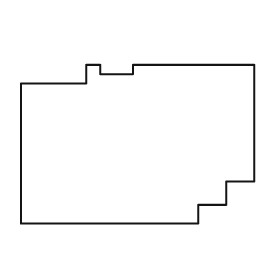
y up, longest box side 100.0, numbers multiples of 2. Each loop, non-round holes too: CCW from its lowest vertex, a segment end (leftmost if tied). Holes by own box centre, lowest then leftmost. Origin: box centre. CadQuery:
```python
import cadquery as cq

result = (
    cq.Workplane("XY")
    .moveTo(-50.0, -34.0)
    .lineTo(26.0, -34.0)
    .lineTo(26.0, -26.0)
    .lineTo(38.0, -26.0)
    .lineTo(38.0, -16.0)
    .lineTo(50.0, -16.0)
    .lineTo(50.0, 34.0)
    .lineTo(-2.0, 34.0)
    .lineTo(-2.0, 30.0)
    .lineTo(-16.0, 30.0)
    .lineTo(-16.0, 34.0)
    .lineTo(-22.0, 34.0)
    .lineTo(-22.0, 26.0)
    .lineTo(-50.0, 26.0)
    .close()
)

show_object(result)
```